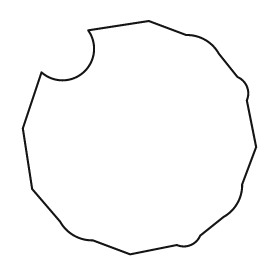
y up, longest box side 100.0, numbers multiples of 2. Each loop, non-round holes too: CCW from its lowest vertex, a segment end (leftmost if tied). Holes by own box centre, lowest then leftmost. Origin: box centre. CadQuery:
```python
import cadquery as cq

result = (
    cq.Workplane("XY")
    .moveTo(-4.0, -50.0)
    .lineTo(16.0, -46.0)
    .threePointArc((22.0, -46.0), (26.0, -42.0))
    .lineTo(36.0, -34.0)
    .threePointArc((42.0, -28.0), (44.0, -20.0))
    .lineTo(50.0, -4.0)
    .lineTo(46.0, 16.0)
    .threePointArc((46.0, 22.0), (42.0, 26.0))
    .lineTo(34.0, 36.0)
    .threePointArc((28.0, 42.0), (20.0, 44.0))
    .lineTo(4.0, 50.0)
    .lineTo(-22.0, 46.0)
    .threePointArc((-24.0, 28.0), (-42.0, 28.0))
    .lineTo(-50.0, 4.0)
    .lineTo(-46.0, -22.0)
    .lineTo(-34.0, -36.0)
    .threePointArc((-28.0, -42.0), (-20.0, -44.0))
    .close()
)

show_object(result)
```